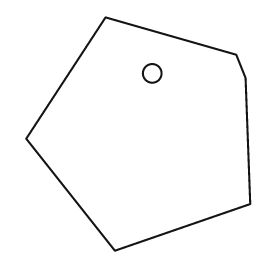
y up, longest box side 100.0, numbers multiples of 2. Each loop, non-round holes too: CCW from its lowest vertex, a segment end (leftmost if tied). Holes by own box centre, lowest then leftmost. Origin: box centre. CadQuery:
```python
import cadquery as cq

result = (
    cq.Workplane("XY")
    .moveTo(-10.0, -50.0)
    .lineTo(48.0, -30.0)
    .lineTo(46.0, 24.0)
    .lineTo(42.0, 34.0)
    .lineTo(-14.0, 50.0)
    .lineTo(-48.0, -2.0)
    .close()
    .moveTo(6.0, 26.0)
    .circle(4.0)
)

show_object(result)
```